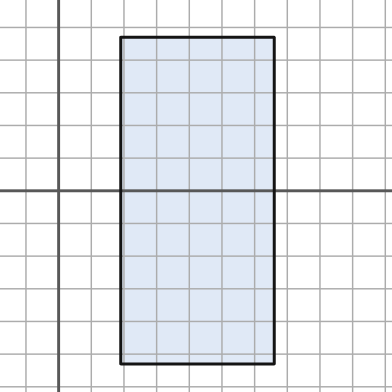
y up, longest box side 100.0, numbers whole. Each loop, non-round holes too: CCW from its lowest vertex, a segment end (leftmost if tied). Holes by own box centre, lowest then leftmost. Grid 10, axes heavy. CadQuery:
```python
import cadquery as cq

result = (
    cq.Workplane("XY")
    .moveTo(19.0, -53.0)
    .lineTo(66.0, -53.0)
    .lineTo(66.0, 47.0)
    .lineTo(19.0, 47.0)
    .close()
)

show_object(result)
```